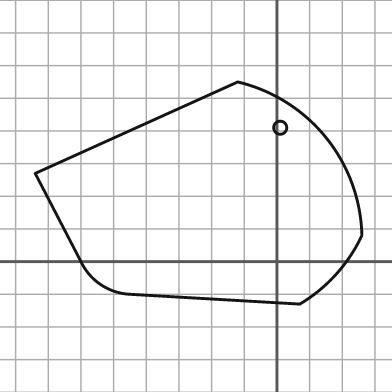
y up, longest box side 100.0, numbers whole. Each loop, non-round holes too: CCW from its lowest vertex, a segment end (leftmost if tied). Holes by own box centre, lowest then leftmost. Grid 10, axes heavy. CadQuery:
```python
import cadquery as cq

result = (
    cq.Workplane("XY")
    .moveTo(7.0, -13.0)
    .threePointArc((18.0, -4.0), (26.0, 8.0))
    .threePointArc((15.0, 38.0), (-12.0, 55.0))
    .lineTo(-74.0, 27.0)
    .lineTo(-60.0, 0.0)
    .threePointArc((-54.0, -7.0), (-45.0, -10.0))
    .close()
    .moveTo(1.0, 41.0)
    .circle(2.0)
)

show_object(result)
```